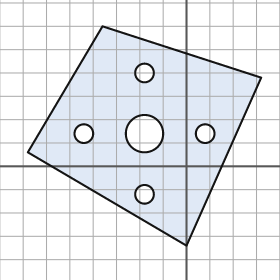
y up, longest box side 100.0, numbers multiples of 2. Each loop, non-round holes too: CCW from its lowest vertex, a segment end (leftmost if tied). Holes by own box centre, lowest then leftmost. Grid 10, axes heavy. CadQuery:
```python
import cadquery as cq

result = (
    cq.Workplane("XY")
    .moveTo(0.0, -34.0)
    .lineTo(32.0, 38.0)
    .lineTo(-36.0, 60.0)
    .lineTo(-68.0, 6.0)
    .close()
    .moveTo(-18.0, -12.0)
    .circle(4.0)
    .moveTo(-44.0, 14.0)
    .circle(4.0)
    .moveTo(-18.0, 14.0)
    .circle(8.0)
    .moveTo(8.0, 14.0)
    .circle(4.0)
    .moveTo(-18.0, 40.0)
    .circle(4.0)
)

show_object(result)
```